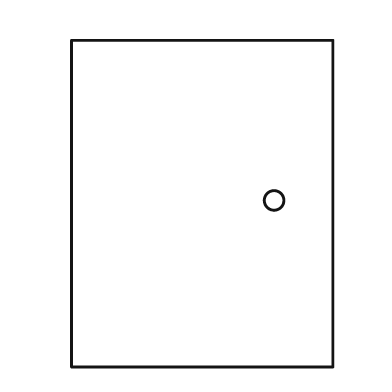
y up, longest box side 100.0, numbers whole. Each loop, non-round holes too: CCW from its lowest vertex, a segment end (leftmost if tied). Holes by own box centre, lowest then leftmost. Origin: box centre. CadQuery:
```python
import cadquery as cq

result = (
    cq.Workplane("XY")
    .moveTo(-40.0, -50.0)
    .lineTo(40.0, -50.0)
    .lineTo(40.0, 50.0)
    .lineTo(-40.0, 50.0)
    .close()
    .moveTo(22.0, 1.0)
    .circle(3.0)
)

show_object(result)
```